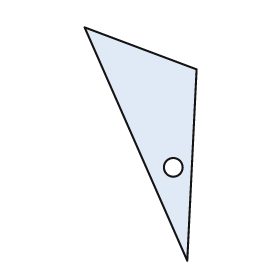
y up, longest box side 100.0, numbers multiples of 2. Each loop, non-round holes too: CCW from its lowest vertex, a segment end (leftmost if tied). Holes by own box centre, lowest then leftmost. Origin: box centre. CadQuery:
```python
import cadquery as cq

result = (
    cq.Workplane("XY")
    .moveTo(20.0, -50.0)
    .lineTo(24.0, 32.0)
    .lineTo(-24.0, 50.0)
    .close()
    .moveTo(14.0, -10.0)
    .circle(4.0)
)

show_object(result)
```